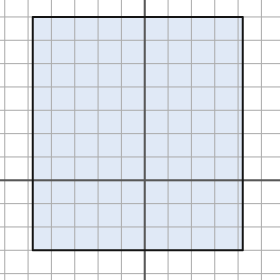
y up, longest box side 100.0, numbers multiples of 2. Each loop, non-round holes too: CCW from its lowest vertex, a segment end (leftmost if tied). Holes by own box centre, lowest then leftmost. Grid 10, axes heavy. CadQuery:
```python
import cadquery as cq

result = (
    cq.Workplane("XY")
    .moveTo(-48.0, -30.0)
    .lineTo(42.0, -30.0)
    .lineTo(42.0, 70.0)
    .lineTo(-48.0, 70.0)
    .close()
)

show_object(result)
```